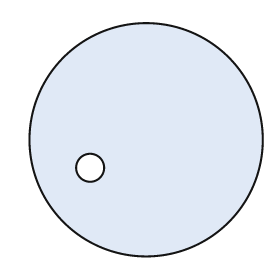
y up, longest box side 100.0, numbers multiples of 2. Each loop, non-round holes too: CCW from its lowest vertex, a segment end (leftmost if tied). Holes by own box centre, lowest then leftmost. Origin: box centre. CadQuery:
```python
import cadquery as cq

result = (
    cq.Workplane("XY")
    .moveTo(0.0, 0.0)
    .circle(50.0)
    .moveTo(-24.0, -12.0)
    .circle(6.0)
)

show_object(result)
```